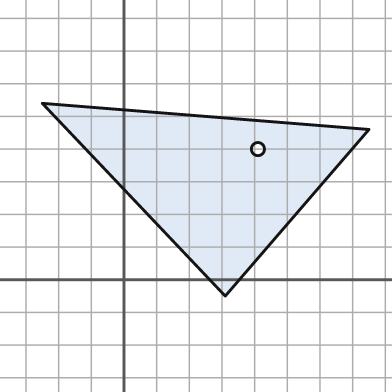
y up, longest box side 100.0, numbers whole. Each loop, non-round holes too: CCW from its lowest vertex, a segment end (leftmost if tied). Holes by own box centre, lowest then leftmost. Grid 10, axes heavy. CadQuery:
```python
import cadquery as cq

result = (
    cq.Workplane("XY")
    .moveTo(31.0, -5.0)
    .lineTo(75.0, 46.0)
    .lineTo(-25.0, 54.0)
    .close()
    .moveTo(41.0, 40.0)
    .circle(2.0)
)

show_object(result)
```